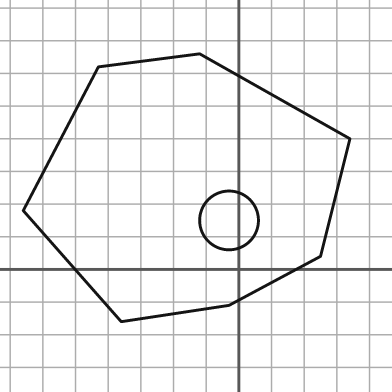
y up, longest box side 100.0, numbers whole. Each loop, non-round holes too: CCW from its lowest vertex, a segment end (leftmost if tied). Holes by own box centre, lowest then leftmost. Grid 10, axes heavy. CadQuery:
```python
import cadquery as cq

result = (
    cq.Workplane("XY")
    .moveTo(-36.0, -16.0)
    .lineTo(-3.0, -11.0)
    .lineTo(25.0, 4.0)
    .lineTo(34.0, 40.0)
    .lineTo(-12.0, 66.0)
    .lineTo(-43.0, 62.0)
    .lineTo(-66.0, 18.0)
    .close()
    .moveTo(-3.0, 15.0)
    .circle(9.0)
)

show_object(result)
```